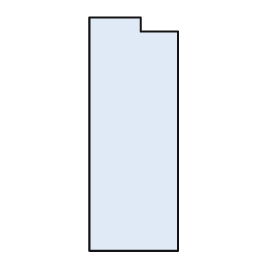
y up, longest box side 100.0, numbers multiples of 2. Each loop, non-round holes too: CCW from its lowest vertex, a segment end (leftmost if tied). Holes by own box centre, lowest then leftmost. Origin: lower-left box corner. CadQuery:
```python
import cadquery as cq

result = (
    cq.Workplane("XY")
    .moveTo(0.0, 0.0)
    .lineTo(38.0, 0.0)
    .lineTo(38.0, 94.0)
    .lineTo(22.0, 94.0)
    .lineTo(22.0, 100.0)
    .lineTo(0.0, 100.0)
    .close()
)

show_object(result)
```